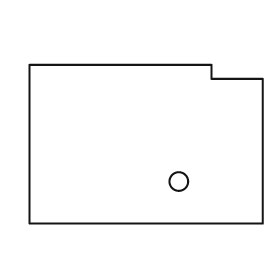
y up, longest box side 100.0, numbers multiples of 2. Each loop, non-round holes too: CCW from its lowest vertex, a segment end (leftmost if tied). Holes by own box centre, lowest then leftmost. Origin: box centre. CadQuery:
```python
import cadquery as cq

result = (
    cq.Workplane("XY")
    .moveTo(-50.0, -34.0)
    .lineTo(50.0, -34.0)
    .lineTo(50.0, 28.0)
    .lineTo(28.0, 28.0)
    .lineTo(28.0, 34.0)
    .lineTo(-50.0, 34.0)
    .close()
    .moveTo(14.0, -16.0)
    .circle(4.0)
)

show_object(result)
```